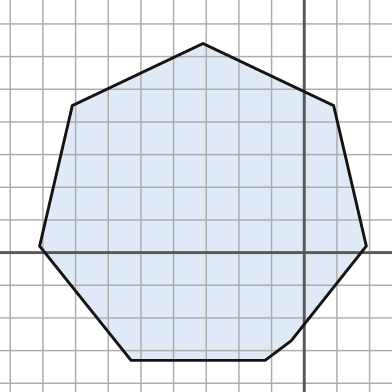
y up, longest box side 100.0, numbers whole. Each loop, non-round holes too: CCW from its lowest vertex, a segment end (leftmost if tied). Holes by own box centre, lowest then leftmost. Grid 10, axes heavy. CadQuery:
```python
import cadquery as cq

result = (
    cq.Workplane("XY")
    .moveTo(-53.0, -33.0)
    .lineTo(-12.0, -33.0)
    .lineTo(-4.0, -27.0)
    .lineTo(19.0, 2.0)
    .lineTo(9.0, 45.0)
    .lineTo(-31.0, 64.0)
    .lineTo(-71.0, 45.0)
    .lineTo(-81.0, 2.0)
    .close()
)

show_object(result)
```